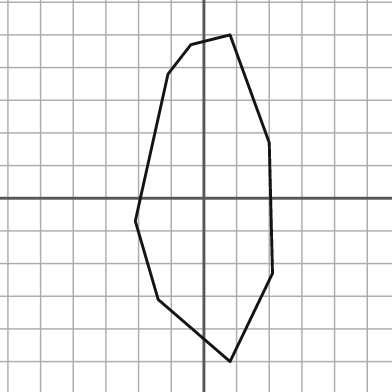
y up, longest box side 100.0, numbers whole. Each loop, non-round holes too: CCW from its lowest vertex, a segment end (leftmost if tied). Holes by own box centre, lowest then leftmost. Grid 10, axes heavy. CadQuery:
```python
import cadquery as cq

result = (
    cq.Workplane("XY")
    .moveTo(8.0, -50.0)
    .lineTo(21.0, -23.0)
    .lineTo(20.0, 17.0)
    .lineTo(8.0, 50.0)
    .lineTo(-4.0, 47.0)
    .lineTo(-11.0, 38.0)
    .lineTo(-21.0, -7.0)
    .lineTo(-14.0, -31.0)
    .close()
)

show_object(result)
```